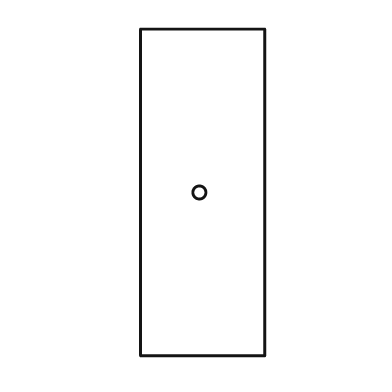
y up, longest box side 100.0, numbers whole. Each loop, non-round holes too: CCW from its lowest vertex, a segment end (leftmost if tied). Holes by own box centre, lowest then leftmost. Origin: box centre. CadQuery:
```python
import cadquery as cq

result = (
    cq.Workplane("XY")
    .moveTo(-19.0, -50.0)
    .lineTo(19.0, -50.0)
    .lineTo(19.0, 50.0)
    .lineTo(-19.0, 50.0)
    .close()
    .moveTo(-1.0, 0.0)
    .circle(2.0)
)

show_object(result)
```